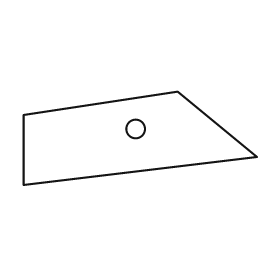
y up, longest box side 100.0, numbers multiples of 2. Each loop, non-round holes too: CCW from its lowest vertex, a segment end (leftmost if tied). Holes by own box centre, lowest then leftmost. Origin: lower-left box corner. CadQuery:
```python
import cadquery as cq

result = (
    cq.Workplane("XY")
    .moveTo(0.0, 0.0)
    .lineTo(100.0, 12.0)
    .lineTo(66.0, 40.0)
    .lineTo(0.0, 30.0)
    .close()
    .moveTo(48.0, 24.0)
    .circle(4.0)
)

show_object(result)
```